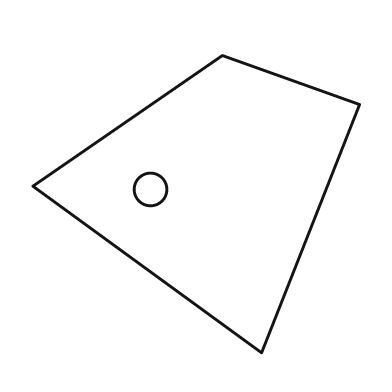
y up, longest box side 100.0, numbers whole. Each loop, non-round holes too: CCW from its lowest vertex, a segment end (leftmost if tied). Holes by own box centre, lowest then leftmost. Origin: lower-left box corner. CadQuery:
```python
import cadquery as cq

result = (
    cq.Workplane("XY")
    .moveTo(70.0, 0.0)
    .lineTo(100.0, 76.0)
    .lineTo(58.0, 91.0)
    .lineTo(0.0, 51.0)
    .close()
    .moveTo(36.0, 50.0)
    .circle(5.0)
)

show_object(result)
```